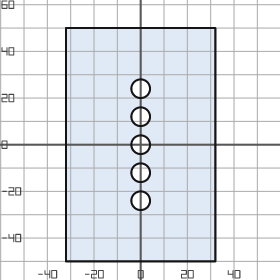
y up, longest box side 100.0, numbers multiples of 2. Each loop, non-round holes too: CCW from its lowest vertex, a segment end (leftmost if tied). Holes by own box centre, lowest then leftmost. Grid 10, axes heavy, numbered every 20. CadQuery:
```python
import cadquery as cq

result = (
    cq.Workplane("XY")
    .moveTo(-32.0, -50.0)
    .lineTo(32.0, -50.0)
    .lineTo(32.0, 50.0)
    .lineTo(-32.0, 50.0)
    .close()
    .moveTo(0.0, -24.0)
    .circle(4.0)
    .moveTo(0.0, -12.0)
    .circle(4.0)
    .moveTo(0.0, 0.0)
    .circle(4.0)
    .moveTo(0.0, 12.0)
    .circle(4.0)
    .moveTo(0.0, 24.0)
    .circle(4.0)
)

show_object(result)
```